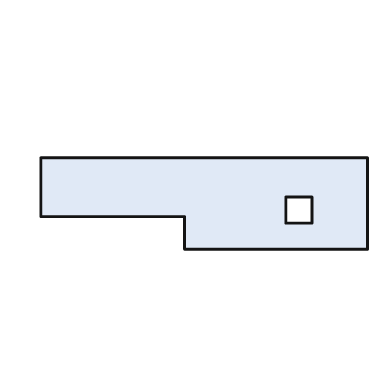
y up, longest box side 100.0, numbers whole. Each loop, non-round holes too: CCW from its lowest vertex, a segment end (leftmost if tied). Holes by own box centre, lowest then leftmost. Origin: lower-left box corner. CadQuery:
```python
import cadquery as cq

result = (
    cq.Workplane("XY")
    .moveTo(44.0, 0.0)
    .lineTo(100.0, 0.0)
    .lineTo(100.0, 28.0)
    .lineTo(0.0, 28.0)
    .lineTo(0.0, 10.0)
    .lineTo(44.0, 10.0)
    .close()
    .moveTo(75.0, 8.0)
    .lineTo(83.0, 8.0)
    .lineTo(83.0, 16.0)
    .lineTo(75.0, 16.0)
    .close()
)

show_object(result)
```